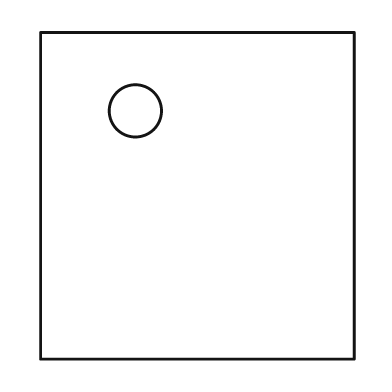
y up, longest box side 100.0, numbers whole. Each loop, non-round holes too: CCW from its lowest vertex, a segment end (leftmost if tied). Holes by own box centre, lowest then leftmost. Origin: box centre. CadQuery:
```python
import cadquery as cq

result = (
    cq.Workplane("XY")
    .moveTo(-48.0, -50.0)
    .lineTo(48.0, -50.0)
    .lineTo(48.0, 50.0)
    .lineTo(-48.0, 50.0)
    .close()
    .moveTo(-19.0, 26.0)
    .circle(8.0)
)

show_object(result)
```